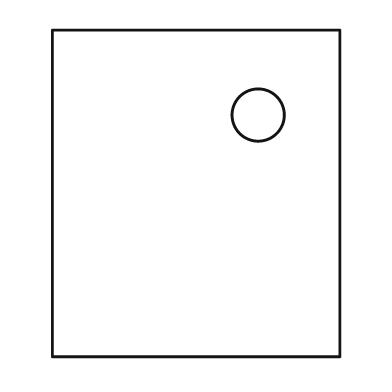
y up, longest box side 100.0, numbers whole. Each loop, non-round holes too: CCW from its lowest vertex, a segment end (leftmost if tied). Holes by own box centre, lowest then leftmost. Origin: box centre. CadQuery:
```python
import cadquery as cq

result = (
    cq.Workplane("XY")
    .moveTo(-44.0, -50.0)
    .lineTo(44.0, -50.0)
    .lineTo(44.0, 50.0)
    .lineTo(-44.0, 50.0)
    .close()
    .moveTo(19.0, 24.0)
    .circle(8.0)
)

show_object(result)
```